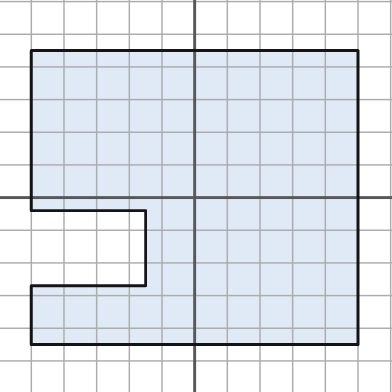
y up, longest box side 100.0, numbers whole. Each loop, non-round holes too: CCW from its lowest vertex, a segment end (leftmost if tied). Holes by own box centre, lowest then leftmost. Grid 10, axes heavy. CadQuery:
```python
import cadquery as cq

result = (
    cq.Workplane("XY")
    .moveTo(-50.0, -45.0)
    .lineTo(50.0, -45.0)
    .lineTo(50.0, 45.0)
    .lineTo(-50.0, 45.0)
    .lineTo(-50.0, -4.0)
    .lineTo(-15.0, -4.0)
    .lineTo(-15.0, -27.0)
    .lineTo(-50.0, -27.0)
    .close()
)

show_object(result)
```